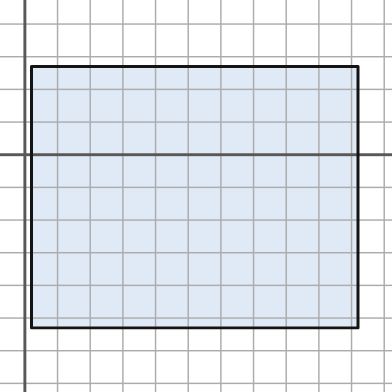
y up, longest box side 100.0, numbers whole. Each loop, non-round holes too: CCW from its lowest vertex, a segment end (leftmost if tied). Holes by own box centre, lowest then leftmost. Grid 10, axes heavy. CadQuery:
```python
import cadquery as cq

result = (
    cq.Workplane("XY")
    .moveTo(2.0, -53.0)
    .lineTo(102.0, -53.0)
    .lineTo(102.0, 27.0)
    .lineTo(2.0, 27.0)
    .close()
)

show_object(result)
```